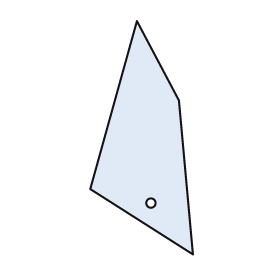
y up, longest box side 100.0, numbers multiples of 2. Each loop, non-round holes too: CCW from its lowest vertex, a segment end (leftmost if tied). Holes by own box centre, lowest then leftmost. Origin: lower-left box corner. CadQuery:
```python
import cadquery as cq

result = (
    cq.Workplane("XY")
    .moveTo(44.0, 0.0)
    .lineTo(38.0, 66.0)
    .lineTo(20.0, 100.0)
    .lineTo(0.0, 28.0)
    .close()
    .moveTo(26.0, 22.0)
    .circle(2.0)
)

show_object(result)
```